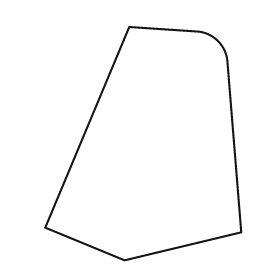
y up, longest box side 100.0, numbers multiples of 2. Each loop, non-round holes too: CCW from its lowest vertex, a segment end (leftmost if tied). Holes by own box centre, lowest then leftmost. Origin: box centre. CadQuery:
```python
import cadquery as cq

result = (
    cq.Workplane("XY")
    .moveTo(-8.0, -50.0)
    .lineTo(42.0, -38.0)
    .lineTo(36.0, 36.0)
    .threePointArc((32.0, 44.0), (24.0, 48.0))
    .lineTo(-6.0, 50.0)
    .lineTo(-42.0, -36.0)
    .close()
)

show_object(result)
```